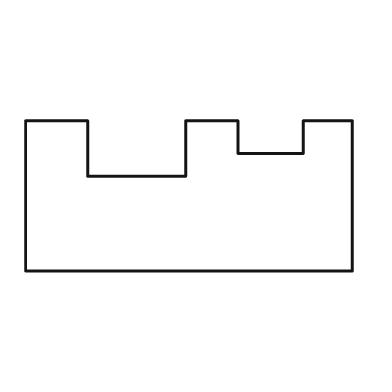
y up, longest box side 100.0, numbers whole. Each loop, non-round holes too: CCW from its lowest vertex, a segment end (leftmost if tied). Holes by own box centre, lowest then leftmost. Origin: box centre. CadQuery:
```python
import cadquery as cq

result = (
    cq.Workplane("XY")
    .moveTo(-50.0, -23.0)
    .lineTo(50.0, -23.0)
    .lineTo(50.0, 23.0)
    .lineTo(35.0, 23.0)
    .lineTo(35.0, 13.0)
    .lineTo(15.0, 13.0)
    .lineTo(15.0, 23.0)
    .lineTo(-1.0, 23.0)
    .lineTo(-1.0, 6.0)
    .lineTo(-31.0, 6.0)
    .lineTo(-31.0, 23.0)
    .lineTo(-50.0, 23.0)
    .close()
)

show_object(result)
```